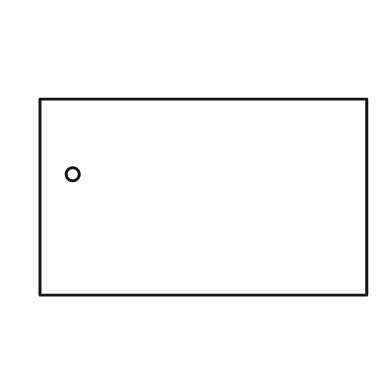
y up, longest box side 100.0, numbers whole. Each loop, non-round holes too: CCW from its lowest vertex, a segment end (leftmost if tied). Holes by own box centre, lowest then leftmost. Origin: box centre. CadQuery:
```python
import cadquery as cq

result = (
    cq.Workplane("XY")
    .moveTo(-50.0, -30.0)
    .lineTo(50.0, -30.0)
    .lineTo(50.0, 30.0)
    .lineTo(-50.0, 30.0)
    .close()
    .moveTo(-40.0, 7.0)
    .circle(2.0)
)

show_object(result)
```